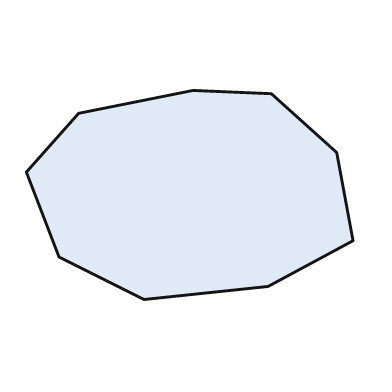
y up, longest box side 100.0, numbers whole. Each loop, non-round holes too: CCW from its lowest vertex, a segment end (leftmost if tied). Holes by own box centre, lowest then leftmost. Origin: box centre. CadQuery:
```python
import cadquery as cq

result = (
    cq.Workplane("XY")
    .moveTo(-14.0, -32.0)
    .lineTo(24.0, -28.0)
    .lineTo(50.0, -14.0)
    .lineTo(45.0, 13.0)
    .lineTo(25.0, 31.0)
    .lineTo(1.0, 32.0)
    .lineTo(-34.0, 25.0)
    .lineTo(-50.0, 7.0)
    .lineTo(-40.0, -19.0)
    .close()
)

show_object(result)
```